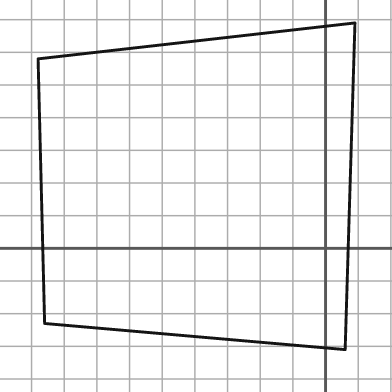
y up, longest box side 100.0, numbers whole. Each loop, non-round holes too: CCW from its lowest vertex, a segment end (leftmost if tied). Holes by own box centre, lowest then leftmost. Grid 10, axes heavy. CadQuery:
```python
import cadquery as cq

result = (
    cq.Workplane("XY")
    .moveTo(6.0, -31.0)
    .lineTo(9.0, 69.0)
    .lineTo(-88.0, 58.0)
    .lineTo(-86.0, -23.0)
    .close()
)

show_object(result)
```